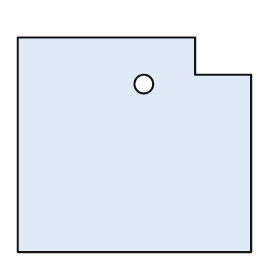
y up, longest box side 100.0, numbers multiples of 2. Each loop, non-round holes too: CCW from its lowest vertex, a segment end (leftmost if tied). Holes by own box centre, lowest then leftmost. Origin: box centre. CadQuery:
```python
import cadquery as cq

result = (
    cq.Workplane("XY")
    .moveTo(-50.0, -46.0)
    .lineTo(50.0, -46.0)
    .lineTo(50.0, 30.0)
    .lineTo(26.0, 30.0)
    .lineTo(26.0, 46.0)
    .lineTo(-50.0, 46.0)
    .close()
    .moveTo(4.0, 26.0)
    .circle(4.0)
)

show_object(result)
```